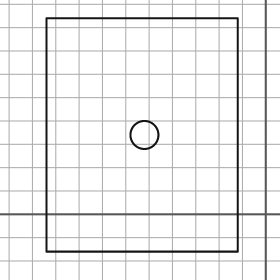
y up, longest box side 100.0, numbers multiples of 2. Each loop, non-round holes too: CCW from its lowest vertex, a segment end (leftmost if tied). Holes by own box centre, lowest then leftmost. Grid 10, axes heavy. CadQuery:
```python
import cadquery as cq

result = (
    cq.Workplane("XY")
    .moveTo(-94.0, -16.0)
    .lineTo(-12.0, -16.0)
    .lineTo(-12.0, 84.0)
    .lineTo(-94.0, 84.0)
    .close()
    .moveTo(-52.0, 34.0)
    .circle(6.0)
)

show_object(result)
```